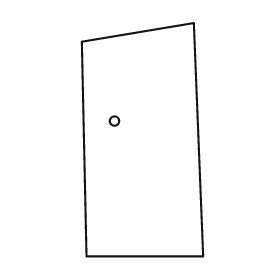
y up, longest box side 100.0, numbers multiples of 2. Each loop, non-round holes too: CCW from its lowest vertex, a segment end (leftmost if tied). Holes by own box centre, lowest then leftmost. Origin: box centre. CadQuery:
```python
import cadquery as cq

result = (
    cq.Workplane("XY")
    .moveTo(-24.0, -50.0)
    .lineTo(26.0, -50.0)
    .lineTo(22.0, 50.0)
    .lineTo(-26.0, 42.0)
    .close()
    .moveTo(-12.0, 8.0)
    .circle(2.0)
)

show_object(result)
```